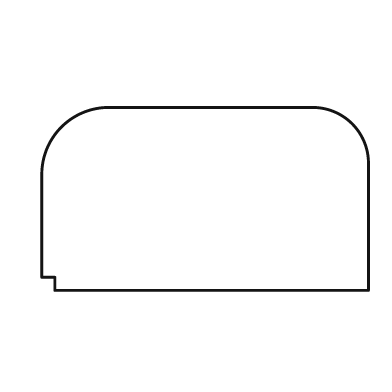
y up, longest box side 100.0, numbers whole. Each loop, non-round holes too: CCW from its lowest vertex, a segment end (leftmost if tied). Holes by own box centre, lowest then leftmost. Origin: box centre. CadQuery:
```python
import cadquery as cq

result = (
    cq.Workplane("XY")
    .moveTo(-46.0, -28.0)
    .lineTo(50.0, -28.0)
    .lineTo(50.0, 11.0)
    .threePointArc((45.0, 23.0), (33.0, 28.0))
    .lineTo(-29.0, 28.0)
    .threePointArc((-44.0, 22.0), (-50.0, 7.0))
    .lineTo(-50.0, -24.0)
    .lineTo(-46.0, -24.0)
    .close()
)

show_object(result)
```